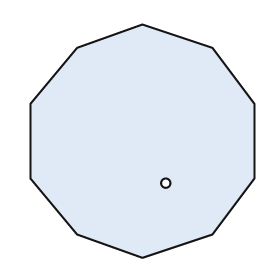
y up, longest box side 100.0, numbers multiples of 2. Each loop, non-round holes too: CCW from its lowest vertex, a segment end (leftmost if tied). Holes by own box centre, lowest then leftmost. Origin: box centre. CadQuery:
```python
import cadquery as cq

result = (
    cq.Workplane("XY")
    .moveTo(0.0, -50.0)
    .lineTo(30.0, -40.0)
    .lineTo(48.0, -16.0)
    .lineTo(48.0, 16.0)
    .lineTo(30.0, 40.0)
    .lineTo(0.0, 50.0)
    .lineTo(-28.0, 40.0)
    .lineTo(-48.0, 16.0)
    .lineTo(-48.0, -16.0)
    .lineTo(-28.0, -40.0)
    .close()
    .moveTo(10.0, -18.0)
    .circle(2.0)
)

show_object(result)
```